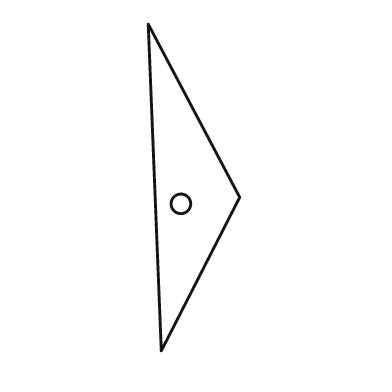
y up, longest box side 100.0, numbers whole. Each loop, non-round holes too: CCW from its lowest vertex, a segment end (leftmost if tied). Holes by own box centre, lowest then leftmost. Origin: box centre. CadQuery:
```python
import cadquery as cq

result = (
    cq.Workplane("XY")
    .moveTo(-10.0, -50.0)
    .lineTo(14.0, -3.0)
    .lineTo(-14.0, 50.0)
    .close()
    .moveTo(-4.0, -5.0)
    .circle(3.0)
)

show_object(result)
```